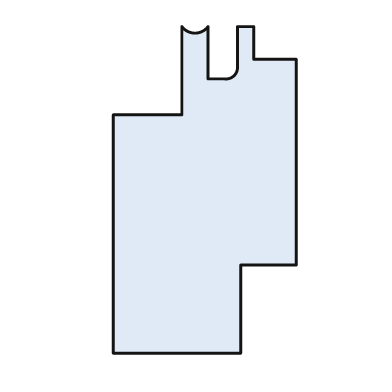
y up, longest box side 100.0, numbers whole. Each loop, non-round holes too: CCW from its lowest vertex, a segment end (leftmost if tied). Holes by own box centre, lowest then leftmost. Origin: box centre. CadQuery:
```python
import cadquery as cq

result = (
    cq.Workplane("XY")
    .moveTo(-28.0, -50.0)
    .lineTo(11.0, -50.0)
    .lineTo(11.0, -23.0)
    .lineTo(28.0, -23.0)
    .lineTo(28.0, 40.0)
    .lineTo(15.0, 40.0)
    .lineTo(15.0, 50.0)
    .lineTo(10.0, 50.0)
    .lineTo(10.0, 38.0)
    .threePointArc((9.0, 35.0), (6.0, 34.0))
    .lineTo(1.0, 34.0)
    .lineTo(1.0, 50.0)
    .threePointArc((-3.0, 48.0), (-7.0, 50.0))
    .lineTo(-7.0, 23.0)
    .lineTo(-28.0, 23.0)
    .close()
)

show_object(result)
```